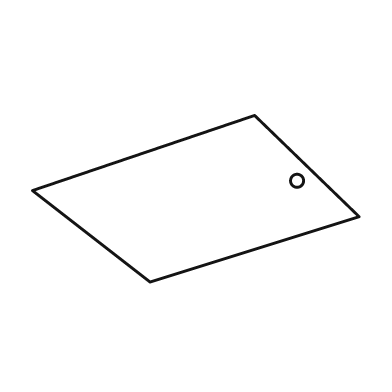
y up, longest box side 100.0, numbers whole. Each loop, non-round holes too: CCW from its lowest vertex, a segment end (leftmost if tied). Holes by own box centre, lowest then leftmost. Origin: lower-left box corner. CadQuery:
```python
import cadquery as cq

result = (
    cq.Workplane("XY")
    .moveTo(36.0, 0.0)
    .lineTo(100.0, 20.0)
    .lineTo(68.0, 51.0)
    .lineTo(0.0, 28.0)
    .close()
    .moveTo(81.0, 31.0)
    .circle(2.0)
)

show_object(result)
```